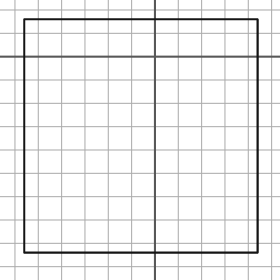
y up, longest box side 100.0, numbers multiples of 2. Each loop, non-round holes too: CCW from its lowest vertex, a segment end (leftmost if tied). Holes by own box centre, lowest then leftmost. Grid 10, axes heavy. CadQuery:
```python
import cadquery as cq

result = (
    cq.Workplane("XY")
    .moveTo(-56.0, -84.0)
    .lineTo(44.0, -84.0)
    .lineTo(44.0, 16.0)
    .lineTo(-56.0, 16.0)
    .close()
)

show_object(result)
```